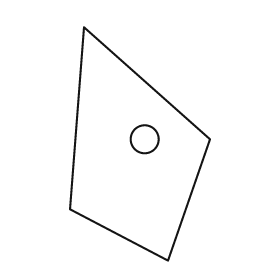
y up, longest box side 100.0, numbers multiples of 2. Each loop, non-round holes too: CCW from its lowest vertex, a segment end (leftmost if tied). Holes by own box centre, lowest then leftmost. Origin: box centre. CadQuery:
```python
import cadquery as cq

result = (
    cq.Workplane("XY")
    .moveTo(12.0, -50.0)
    .lineTo(30.0, 2.0)
    .lineTo(-24.0, 50.0)
    .lineTo(-30.0, -28.0)
    .close()
    .moveTo(2.0, 2.0)
    .circle(6.0)
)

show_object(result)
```